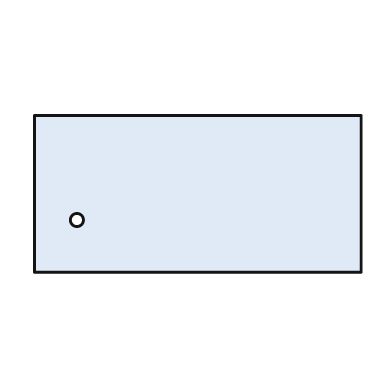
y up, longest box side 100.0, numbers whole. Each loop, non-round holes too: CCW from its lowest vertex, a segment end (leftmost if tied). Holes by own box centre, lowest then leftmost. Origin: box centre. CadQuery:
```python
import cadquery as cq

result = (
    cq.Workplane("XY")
    .moveTo(-50.0, -24.0)
    .lineTo(50.0, -24.0)
    .lineTo(50.0, 24.0)
    .lineTo(-50.0, 24.0)
    .close()
    .moveTo(-37.0, -8.0)
    .circle(2.0)
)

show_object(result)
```